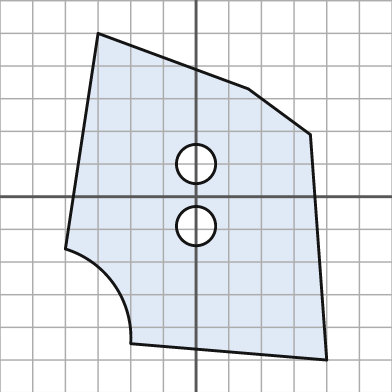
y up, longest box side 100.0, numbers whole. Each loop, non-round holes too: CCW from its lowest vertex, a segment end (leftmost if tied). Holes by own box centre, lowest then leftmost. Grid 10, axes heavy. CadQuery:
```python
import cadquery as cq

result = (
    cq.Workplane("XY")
    .moveTo(40.0, -50.0)
    .lineTo(35.0, 19.0)
    .lineTo(16.0, 33.0)
    .lineTo(-30.0, 50.0)
    .lineTo(-40.0, -16.0)
    .threePointArc((-25.0, -27.0), (-20.0, -45.0))
    .close()
    .moveTo(0.0, -9.0)
    .circle(6.0)
    .moveTo(0.0, 10.0)
    .circle(6.0)
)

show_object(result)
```